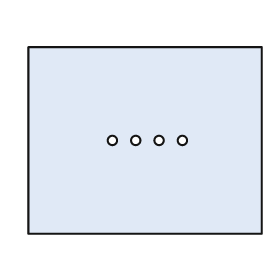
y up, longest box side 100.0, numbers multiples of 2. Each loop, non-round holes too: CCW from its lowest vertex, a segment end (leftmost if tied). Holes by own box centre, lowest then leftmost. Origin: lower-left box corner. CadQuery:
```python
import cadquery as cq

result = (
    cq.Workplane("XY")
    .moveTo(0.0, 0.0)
    .lineTo(100.0, 0.0)
    .lineTo(100.0, 80.0)
    .lineTo(0.0, 80.0)
    .close()
    .moveTo(36.0, 40.0)
    .circle(2.0)
    .moveTo(46.0, 40.0)
    .circle(2.0)
    .moveTo(56.0, 40.0)
    .circle(2.0)
    .moveTo(66.0, 40.0)
    .circle(2.0)
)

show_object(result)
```